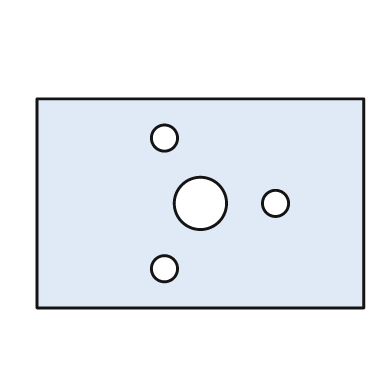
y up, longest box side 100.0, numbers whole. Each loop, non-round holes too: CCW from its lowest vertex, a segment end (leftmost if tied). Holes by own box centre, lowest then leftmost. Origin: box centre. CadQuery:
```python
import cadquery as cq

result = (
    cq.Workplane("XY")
    .moveTo(-50.0, -32.0)
    .lineTo(50.0, -32.0)
    .lineTo(50.0, 32.0)
    .lineTo(-50.0, 32.0)
    .close()
    .moveTo(-11.0, -20.0)
    .circle(4.0)
    .moveTo(0.0, 0.0)
    .circle(8.0)
    .moveTo(23.0, 0.0)
    .circle(4.0)
    .moveTo(-11.0, 20.0)
    .circle(4.0)
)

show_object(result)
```